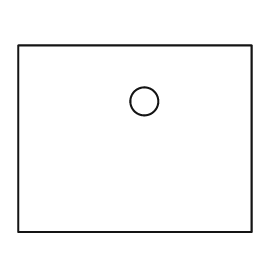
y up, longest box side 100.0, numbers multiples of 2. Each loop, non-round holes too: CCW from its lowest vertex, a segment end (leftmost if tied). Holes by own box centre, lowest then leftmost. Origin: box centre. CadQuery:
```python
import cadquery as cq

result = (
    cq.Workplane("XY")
    .moveTo(-50.0, -40.0)
    .lineTo(50.0, -40.0)
    .lineTo(50.0, 40.0)
    .lineTo(-50.0, 40.0)
    .close()
    .moveTo(4.0, 16.0)
    .circle(6.0)
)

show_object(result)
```